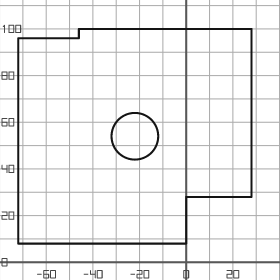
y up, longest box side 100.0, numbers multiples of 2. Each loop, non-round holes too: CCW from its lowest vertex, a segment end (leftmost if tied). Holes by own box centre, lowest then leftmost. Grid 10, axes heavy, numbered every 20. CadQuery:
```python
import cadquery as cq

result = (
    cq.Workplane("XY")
    .moveTo(-72.0, 8.0)
    .lineTo(0.0, 8.0)
    .lineTo(0.0, 28.0)
    .lineTo(28.0, 28.0)
    .lineTo(28.0, 100.0)
    .lineTo(-46.0, 100.0)
    .lineTo(-46.0, 96.0)
    .lineTo(-72.0, 96.0)
    .close()
    .moveTo(-22.0, 54.0)
    .circle(10.0)
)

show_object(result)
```